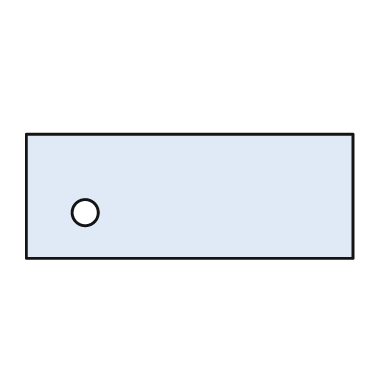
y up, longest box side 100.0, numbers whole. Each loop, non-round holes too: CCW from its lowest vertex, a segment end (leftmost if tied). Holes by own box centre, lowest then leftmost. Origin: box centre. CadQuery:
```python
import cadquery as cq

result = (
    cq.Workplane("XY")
    .moveTo(-50.0, -19.0)
    .lineTo(50.0, -19.0)
    .lineTo(50.0, 19.0)
    .lineTo(-50.0, 19.0)
    .close()
    .moveTo(-32.0, -5.0)
    .circle(4.0)
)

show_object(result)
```